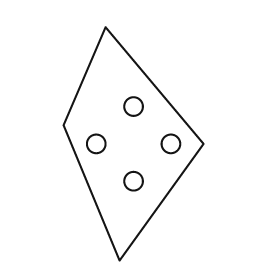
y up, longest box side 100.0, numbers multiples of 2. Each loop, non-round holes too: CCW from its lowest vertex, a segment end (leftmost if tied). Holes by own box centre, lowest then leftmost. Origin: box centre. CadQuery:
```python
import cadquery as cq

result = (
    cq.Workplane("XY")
    .moveTo(-6.0, -50.0)
    .lineTo(30.0, 0.0)
    .lineTo(-12.0, 50.0)
    .lineTo(-30.0, 8.0)
    .close()
    .moveTo(0.0, -16.0)
    .circle(4.0)
    .moveTo(-16.0, 0.0)
    .circle(4.0)
    .moveTo(16.0, 0.0)
    .circle(4.0)
    .moveTo(0.0, 16.0)
    .circle(4.0)
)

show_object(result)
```